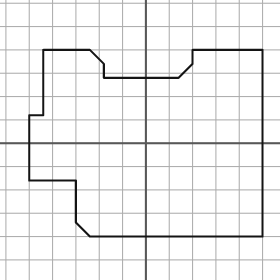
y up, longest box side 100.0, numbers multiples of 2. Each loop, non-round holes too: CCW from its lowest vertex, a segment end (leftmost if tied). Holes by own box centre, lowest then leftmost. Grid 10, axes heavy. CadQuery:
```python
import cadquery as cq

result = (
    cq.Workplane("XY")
    .moveTo(-24.0, -40.0)
    .lineTo(50.0, -40.0)
    .lineTo(50.0, 40.0)
    .lineTo(20.0, 40.0)
    .lineTo(20.0, 34.0)
    .lineTo(14.0, 28.0)
    .lineTo(-18.0, 28.0)
    .lineTo(-18.0, 34.0)
    .lineTo(-24.0, 40.0)
    .lineTo(-44.0, 40.0)
    .lineTo(-44.0, 12.0)
    .lineTo(-50.0, 12.0)
    .lineTo(-50.0, -16.0)
    .lineTo(-30.0, -16.0)
    .lineTo(-30.0, -34.0)
    .close()
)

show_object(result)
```